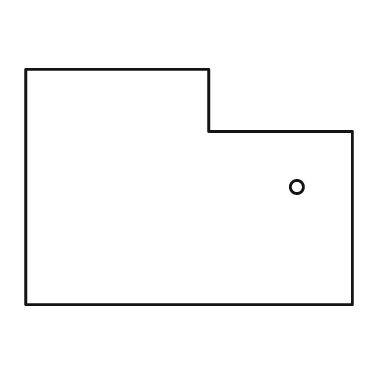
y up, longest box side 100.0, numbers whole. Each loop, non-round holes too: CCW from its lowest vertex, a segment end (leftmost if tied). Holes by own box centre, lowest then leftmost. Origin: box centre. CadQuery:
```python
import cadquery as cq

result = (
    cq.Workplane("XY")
    .moveTo(-50.0, -36.0)
    .lineTo(50.0, -36.0)
    .lineTo(50.0, 17.0)
    .lineTo(6.0, 17.0)
    .lineTo(6.0, 36.0)
    .lineTo(-50.0, 36.0)
    .close()
    .moveTo(33.0, 0.0)
    .circle(2.0)
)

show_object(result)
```